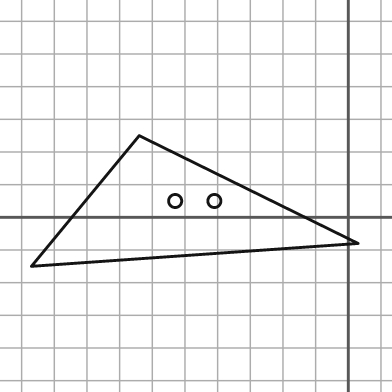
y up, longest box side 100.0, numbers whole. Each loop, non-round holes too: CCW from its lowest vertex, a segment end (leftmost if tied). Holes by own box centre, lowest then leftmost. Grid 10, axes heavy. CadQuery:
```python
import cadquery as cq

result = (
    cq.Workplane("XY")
    .moveTo(-97.0, -15.0)
    .lineTo(3.0, -8.0)
    .lineTo(-64.0, 25.0)
    .close()
    .moveTo(-53.0, 5.0)
    .circle(2.0)
    .moveTo(-41.0, 5.0)
    .circle(2.0)
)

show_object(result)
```